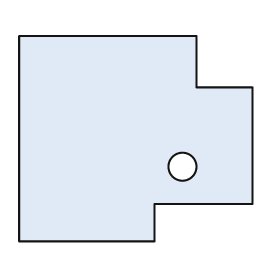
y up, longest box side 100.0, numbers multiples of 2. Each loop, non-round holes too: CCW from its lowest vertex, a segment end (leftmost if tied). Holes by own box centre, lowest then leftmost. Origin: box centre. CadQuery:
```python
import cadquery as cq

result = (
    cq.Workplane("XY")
    .moveTo(-50.0, -44.0)
    .lineTo(8.0, -44.0)
    .lineTo(8.0, -28.0)
    .lineTo(50.0, -28.0)
    .lineTo(50.0, 22.0)
    .lineTo(26.0, 22.0)
    .lineTo(26.0, 44.0)
    .lineTo(-50.0, 44.0)
    .close()
    .moveTo(20.0, -12.0)
    .circle(6.0)
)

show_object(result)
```